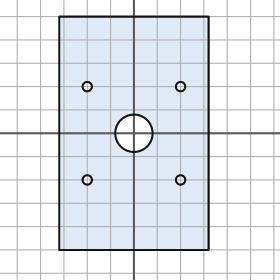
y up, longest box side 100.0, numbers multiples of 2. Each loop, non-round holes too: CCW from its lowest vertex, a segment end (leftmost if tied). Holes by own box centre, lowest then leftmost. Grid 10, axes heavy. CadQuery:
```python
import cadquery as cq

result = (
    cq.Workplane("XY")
    .moveTo(-32.0, -50.0)
    .lineTo(32.0, -50.0)
    .lineTo(32.0, 50.0)
    .lineTo(-32.0, 50.0)
    .close()
    .moveTo(-20.0, -20.0)
    .circle(2.0)
    .moveTo(20.0, -20.0)
    .circle(2.0)
    .moveTo(0.0, 0.0)
    .circle(8.0)
    .moveTo(-20.0, 20.0)
    .circle(2.0)
    .moveTo(20.0, 20.0)
    .circle(2.0)
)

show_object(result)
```